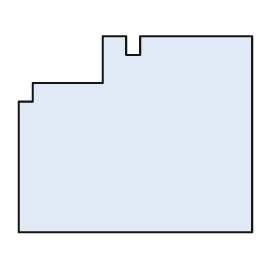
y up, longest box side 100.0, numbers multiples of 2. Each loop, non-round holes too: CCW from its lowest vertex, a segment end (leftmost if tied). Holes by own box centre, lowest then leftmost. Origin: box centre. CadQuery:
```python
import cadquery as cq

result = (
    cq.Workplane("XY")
    .moveTo(-50.0, -42.0)
    .lineTo(50.0, -42.0)
    .lineTo(50.0, 42.0)
    .lineTo(2.0, 42.0)
    .lineTo(2.0, 34.0)
    .lineTo(-4.0, 34.0)
    .lineTo(-4.0, 42.0)
    .lineTo(-14.0, 42.0)
    .lineTo(-14.0, 22.0)
    .lineTo(-44.0, 22.0)
    .lineTo(-44.0, 14.0)
    .lineTo(-50.0, 14.0)
    .close()
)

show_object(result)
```